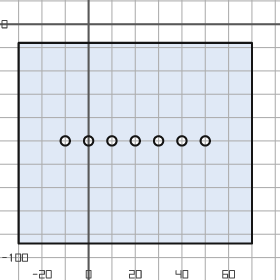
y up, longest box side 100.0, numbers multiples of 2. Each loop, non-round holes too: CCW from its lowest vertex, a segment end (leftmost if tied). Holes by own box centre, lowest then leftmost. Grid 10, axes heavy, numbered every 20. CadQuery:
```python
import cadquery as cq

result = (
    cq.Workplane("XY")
    .moveTo(-30.0, -94.0)
    .lineTo(70.0, -94.0)
    .lineTo(70.0, -8.0)
    .lineTo(-30.0, -8.0)
    .close()
    .moveTo(-10.0, -50.0)
    .circle(2.0)
    .moveTo(0.0, -50.0)
    .circle(2.0)
    .moveTo(10.0, -50.0)
    .circle(2.0)
    .moveTo(20.0, -50.0)
    .circle(2.0)
    .moveTo(30.0, -50.0)
    .circle(2.0)
    .moveTo(40.0, -50.0)
    .circle(2.0)
    .moveTo(50.0, -50.0)
    .circle(2.0)
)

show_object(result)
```